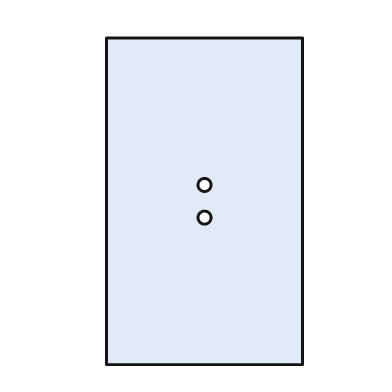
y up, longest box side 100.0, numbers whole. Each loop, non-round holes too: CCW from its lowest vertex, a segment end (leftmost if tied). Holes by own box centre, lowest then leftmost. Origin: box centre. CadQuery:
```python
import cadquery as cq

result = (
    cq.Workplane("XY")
    .moveTo(-30.0, -50.0)
    .lineTo(30.0, -50.0)
    .lineTo(30.0, 50.0)
    .lineTo(-30.0, 50.0)
    .close()
    .moveTo(0.0, -5.0)
    .circle(2.0)
    .moveTo(0.0, 5.0)
    .circle(2.0)
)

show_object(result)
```